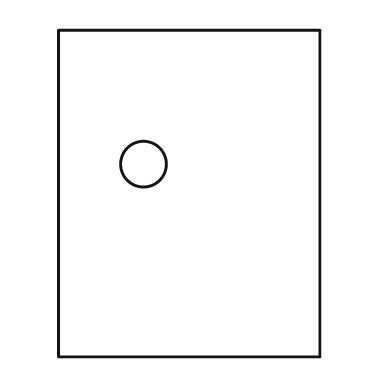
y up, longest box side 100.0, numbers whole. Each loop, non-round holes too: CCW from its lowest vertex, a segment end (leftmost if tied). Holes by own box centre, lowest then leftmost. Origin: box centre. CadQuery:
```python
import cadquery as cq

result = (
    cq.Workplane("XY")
    .moveTo(-40.0, -50.0)
    .lineTo(40.0, -50.0)
    .lineTo(40.0, 50.0)
    .lineTo(-40.0, 50.0)
    .close()
    .moveTo(-14.0, 9.0)
    .circle(7.0)
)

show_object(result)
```